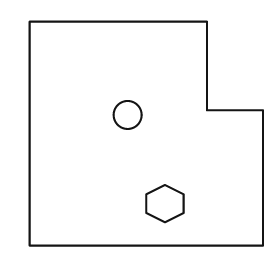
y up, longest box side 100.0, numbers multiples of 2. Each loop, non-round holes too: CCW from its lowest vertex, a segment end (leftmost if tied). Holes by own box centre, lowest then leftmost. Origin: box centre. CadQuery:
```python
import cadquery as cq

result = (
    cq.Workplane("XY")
    .moveTo(-50.0, -48.0)
    .lineTo(50.0, -48.0)
    .lineTo(50.0, 10.0)
    .lineTo(26.0, 10.0)
    .lineTo(26.0, 48.0)
    .lineTo(-50.0, 48.0)
    .close()
    .moveTo(8.0, -38.0)
    .lineTo(16.0, -34.0)
    .lineTo(16.0, -26.0)
    .lineTo(8.0, -22.0)
    .lineTo(0.0, -26.0)
    .lineTo(0.0, -34.0)
    .close()
    .moveTo(-8.0, 8.0)
    .circle(6.0)
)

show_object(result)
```